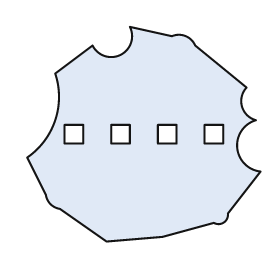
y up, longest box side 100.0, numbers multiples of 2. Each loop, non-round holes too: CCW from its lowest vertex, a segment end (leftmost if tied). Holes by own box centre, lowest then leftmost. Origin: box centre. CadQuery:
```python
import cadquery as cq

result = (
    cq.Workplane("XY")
    .moveTo(-16.0, -46.0)
    .lineTo(8.0, -44.0)
    .lineTo(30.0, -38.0)
    .threePointArc((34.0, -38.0), (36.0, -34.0))
    .lineTo(50.0, -16.0)
    .threePointArc((40.0, -6.0), (48.0, 6.0))
    .threePointArc((42.0, 12.0), (44.0, 20.0))
    .lineTo(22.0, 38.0)
    .threePointArc((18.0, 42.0), (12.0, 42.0))
    .lineTo(-6.0, 46.0)
    .threePointArc((-10.0, 34.0), (-22.0, 38.0))
    .lineTo(-38.0, 26.0)
    .threePointArc((-38.0, 6.0), (-50.0, -10.0))
    .lineTo(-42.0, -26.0)
    .threePointArc((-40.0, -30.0), (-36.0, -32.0))
    .close()
    .moveTo(-34.0, -4.0)
    .lineTo(-26.0, -4.0)
    .lineTo(-26.0, 4.0)
    .lineTo(-34.0, 4.0)
    .close()
    .moveTo(-14.0, -4.0)
    .lineTo(-6.0, -4.0)
    .lineTo(-6.0, 4.0)
    .lineTo(-14.0, 4.0)
    .close()
    .moveTo(6.0, -4.0)
    .lineTo(14.0, -4.0)
    .lineTo(14.0, 4.0)
    .lineTo(6.0, 4.0)
    .close()
    .moveTo(26.0, -4.0)
    .lineTo(34.0, -4.0)
    .lineTo(34.0, 4.0)
    .lineTo(26.0, 4.0)
    .close()
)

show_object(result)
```